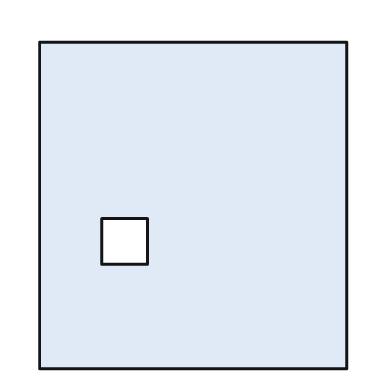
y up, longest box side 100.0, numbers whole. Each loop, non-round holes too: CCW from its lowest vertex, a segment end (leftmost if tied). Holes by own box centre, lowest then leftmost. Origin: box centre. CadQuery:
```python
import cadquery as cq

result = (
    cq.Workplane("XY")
    .moveTo(-47.0, -50.0)
    .lineTo(47.0, -50.0)
    .lineTo(47.0, 50.0)
    .lineTo(-47.0, 50.0)
    .close()
    .moveTo(-28.0, -18.0)
    .lineTo(-14.0, -18.0)
    .lineTo(-14.0, -4.0)
    .lineTo(-28.0, -4.0)
    .close()
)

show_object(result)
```